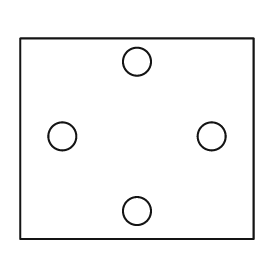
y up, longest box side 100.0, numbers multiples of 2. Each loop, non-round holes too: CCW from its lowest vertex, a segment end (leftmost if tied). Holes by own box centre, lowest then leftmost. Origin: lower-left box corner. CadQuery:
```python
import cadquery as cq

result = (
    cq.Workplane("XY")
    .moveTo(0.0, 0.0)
    .lineTo(100.0, 0.0)
    .lineTo(100.0, 86.0)
    .lineTo(0.0, 86.0)
    .close()
    .moveTo(50.0, 12.0)
    .circle(6.0)
    .moveTo(18.0, 44.0)
    .circle(6.0)
    .moveTo(82.0, 44.0)
    .circle(6.0)
    .moveTo(50.0, 76.0)
    .circle(6.0)
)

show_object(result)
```